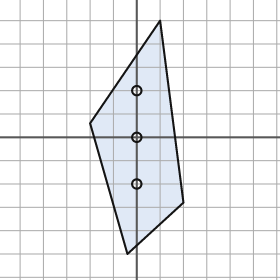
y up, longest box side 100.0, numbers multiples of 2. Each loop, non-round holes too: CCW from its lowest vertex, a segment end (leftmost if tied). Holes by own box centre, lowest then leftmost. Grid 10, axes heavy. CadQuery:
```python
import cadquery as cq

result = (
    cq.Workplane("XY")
    .moveTo(-4.0, -50.0)
    .lineTo(20.0, -28.0)
    .lineTo(10.0, 50.0)
    .lineTo(-20.0, 6.0)
    .close()
    .moveTo(0.0, -20.0)
    .circle(2.0)
    .moveTo(0.0, 0.0)
    .circle(2.0)
    .moveTo(0.0, 20.0)
    .circle(2.0)
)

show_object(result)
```